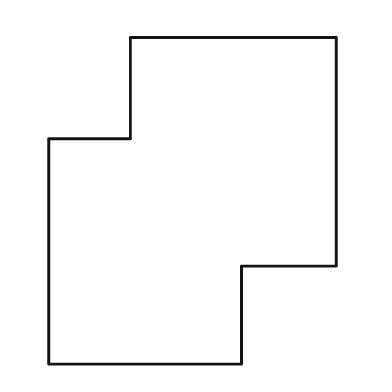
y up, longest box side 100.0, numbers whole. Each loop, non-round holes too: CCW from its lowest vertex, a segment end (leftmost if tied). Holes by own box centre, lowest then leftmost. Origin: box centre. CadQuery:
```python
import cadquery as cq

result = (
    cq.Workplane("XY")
    .moveTo(-44.0, -50.0)
    .lineTo(15.0, -50.0)
    .lineTo(15.0, -20.0)
    .lineTo(44.0, -20.0)
    .lineTo(44.0, 50.0)
    .lineTo(-19.0, 50.0)
    .lineTo(-19.0, 19.0)
    .lineTo(-44.0, 19.0)
    .close()
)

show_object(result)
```